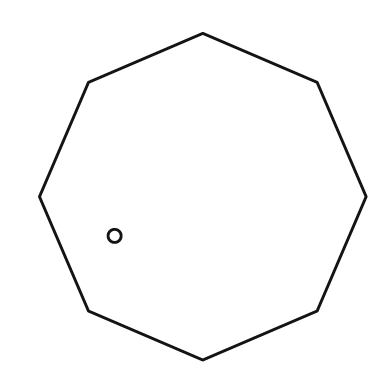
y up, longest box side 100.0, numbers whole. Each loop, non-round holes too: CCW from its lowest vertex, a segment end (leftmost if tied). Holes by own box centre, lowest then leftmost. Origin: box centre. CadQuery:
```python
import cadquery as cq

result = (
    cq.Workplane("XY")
    .moveTo(0.0, -50.0)
    .lineTo(35.0, -35.0)
    .lineTo(50.0, 0.0)
    .lineTo(35.0, 35.0)
    .lineTo(0.0, 50.0)
    .lineTo(-35.0, 35.0)
    .lineTo(-50.0, 0.0)
    .lineTo(-35.0, -35.0)
    .close()
    .moveTo(-27.0, -12.0)
    .circle(2.0)
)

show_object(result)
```